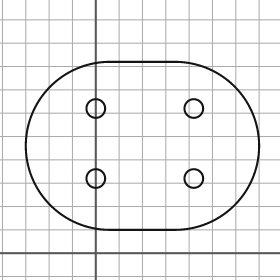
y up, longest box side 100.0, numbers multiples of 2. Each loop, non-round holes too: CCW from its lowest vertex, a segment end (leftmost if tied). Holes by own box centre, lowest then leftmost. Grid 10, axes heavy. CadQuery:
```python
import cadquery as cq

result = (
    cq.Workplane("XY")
    .moveTo(6.0, 10.0)
    .lineTo(34.0, 10.0)
    .threePointArc((70.0, 46.0), (34.0, 82.0))
    .lineTo(6.0, 82.0)
    .threePointArc((-30.0, 46.0), (6.0, 10.0))
    .close()
    .moveTo(0.0, 32.0)
    .circle(4.0)
    .moveTo(42.0, 32.0)
    .circle(4.0)
    .moveTo(0.0, 62.0)
    .circle(4.0)
    .moveTo(42.0, 62.0)
    .circle(4.0)
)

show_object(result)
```